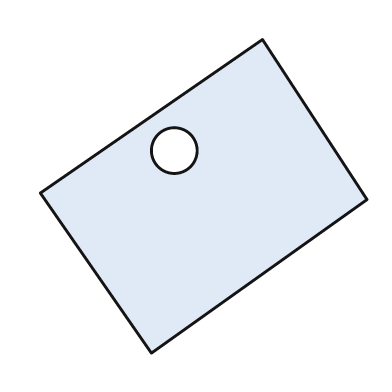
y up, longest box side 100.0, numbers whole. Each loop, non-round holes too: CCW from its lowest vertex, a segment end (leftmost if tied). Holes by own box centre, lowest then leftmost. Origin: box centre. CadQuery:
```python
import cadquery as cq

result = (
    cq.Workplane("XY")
    .moveTo(-16.0, -48.0)
    .lineTo(50.0, -1.0)
    .lineTo(18.0, 48.0)
    .lineTo(-50.0, 1.0)
    .close()
    .moveTo(-9.0, 14.0)
    .circle(7.0)
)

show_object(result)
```